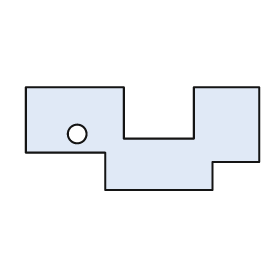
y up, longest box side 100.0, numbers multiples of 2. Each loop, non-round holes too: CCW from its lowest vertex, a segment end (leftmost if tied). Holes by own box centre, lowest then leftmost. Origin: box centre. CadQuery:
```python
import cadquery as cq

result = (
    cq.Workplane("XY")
    .moveTo(-16.0, -22.0)
    .lineTo(30.0, -22.0)
    .lineTo(30.0, -10.0)
    .lineTo(50.0, -10.0)
    .lineTo(50.0, 22.0)
    .lineTo(22.0, 22.0)
    .lineTo(22.0, 0.0)
    .lineTo(-8.0, 0.0)
    .lineTo(-8.0, 22.0)
    .lineTo(-50.0, 22.0)
    .lineTo(-50.0, -6.0)
    .lineTo(-16.0, -6.0)
    .close()
    .moveTo(-28.0, 2.0)
    .circle(4.0)
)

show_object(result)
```